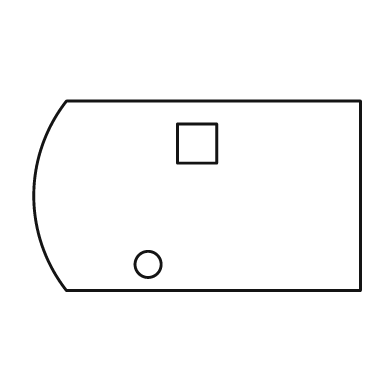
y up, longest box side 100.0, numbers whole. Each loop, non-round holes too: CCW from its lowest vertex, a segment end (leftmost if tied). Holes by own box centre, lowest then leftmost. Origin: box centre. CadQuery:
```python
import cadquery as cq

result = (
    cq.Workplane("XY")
    .moveTo(-40.0, -29.0)
    .lineTo(50.0, -29.0)
    .lineTo(50.0, 29.0)
    .lineTo(-40.0, 29.0)
    .threePointArc((-50.0, 0.0), (-40.0, -29.0))
    .close()
    .moveTo(-15.0, -21.0)
    .circle(4.0)
    .moveTo(-6.0, 10.0)
    .lineTo(6.0, 10.0)
    .lineTo(6.0, 22.0)
    .lineTo(-6.0, 22.0)
    .close()
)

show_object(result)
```